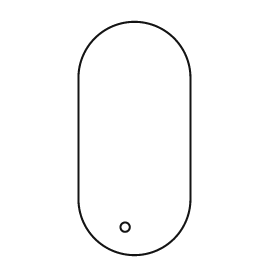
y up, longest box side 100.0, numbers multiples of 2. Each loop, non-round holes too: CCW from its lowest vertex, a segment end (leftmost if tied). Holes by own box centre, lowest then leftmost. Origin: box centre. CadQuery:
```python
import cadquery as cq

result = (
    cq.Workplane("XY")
    .moveTo(-24.0, -26.0)
    .threePointArc((0.0, -50.0), (24.0, -26.0))
    .lineTo(24.0, 26.0)
    .threePointArc((0.0, 50.0), (-24.0, 26.0))
    .close()
    .moveTo(-4.0, -38.0)
    .circle(2.0)
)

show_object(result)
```